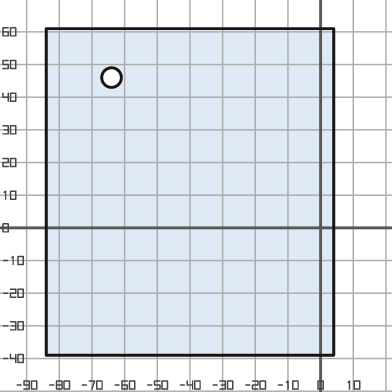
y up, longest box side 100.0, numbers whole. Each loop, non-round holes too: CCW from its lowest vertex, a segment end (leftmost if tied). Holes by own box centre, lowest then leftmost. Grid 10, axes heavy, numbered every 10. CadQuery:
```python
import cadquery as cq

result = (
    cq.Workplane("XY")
    .moveTo(-84.0, -39.0)
    .lineTo(4.0, -39.0)
    .lineTo(4.0, 61.0)
    .lineTo(-84.0, 61.0)
    .close()
    .moveTo(-64.0, 46.0)
    .circle(3.0)
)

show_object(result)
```